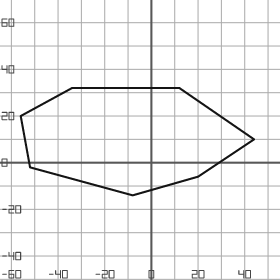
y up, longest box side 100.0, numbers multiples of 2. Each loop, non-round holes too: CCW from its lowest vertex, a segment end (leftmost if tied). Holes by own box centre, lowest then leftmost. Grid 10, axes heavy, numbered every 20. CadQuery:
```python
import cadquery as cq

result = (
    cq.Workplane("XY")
    .moveTo(-8.0, -14.0)
    .lineTo(20.0, -6.0)
    .lineTo(44.0, 10.0)
    .lineTo(12.0, 32.0)
    .lineTo(-34.0, 32.0)
    .lineTo(-56.0, 20.0)
    .lineTo(-52.0, -2.0)
    .close()
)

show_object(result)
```